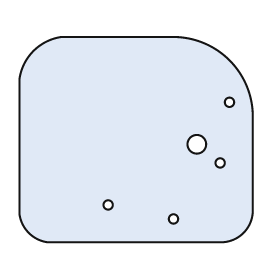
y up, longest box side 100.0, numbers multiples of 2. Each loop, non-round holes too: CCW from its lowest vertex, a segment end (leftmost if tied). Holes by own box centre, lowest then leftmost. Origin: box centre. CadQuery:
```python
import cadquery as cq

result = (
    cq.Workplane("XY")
    .moveTo(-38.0, -44.0)
    .lineTo(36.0, -44.0)
    .threePointArc((46.0, -40.0), (50.0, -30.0))
    .lineTo(50.0, 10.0)
    .threePointArc((40.0, 34.0), (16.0, 44.0))
    .lineTo(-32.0, 44.0)
    .threePointArc((-44.0, 38.0), (-50.0, 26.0))
    .lineTo(-50.0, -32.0)
    .threePointArc((-46.0, -40.0), (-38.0, -44.0))
    .close()
    .moveTo(16.0, -34.0)
    .circle(2.0)
    .moveTo(-12.0, -28.0)
    .circle(2.0)
    .moveTo(36.0, -10.0)
    .circle(2.0)
    .moveTo(26.0, -2.0)
    .circle(4.0)
    .moveTo(40.0, 16.0)
    .circle(2.0)
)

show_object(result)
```